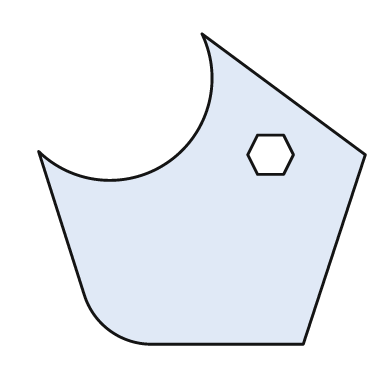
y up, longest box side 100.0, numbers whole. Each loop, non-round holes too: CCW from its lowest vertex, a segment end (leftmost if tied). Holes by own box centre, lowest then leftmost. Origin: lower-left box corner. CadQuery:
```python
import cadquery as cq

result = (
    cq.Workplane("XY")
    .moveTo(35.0, 0.0)
    .lineTo(81.0, 0.0)
    .lineTo(100.0, 58.0)
    .lineTo(50.0, 95.0)
    .threePointArc((40.0, 56.0), (0.0, 59.0))
    .lineTo(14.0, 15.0)
    .threePointArc((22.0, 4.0), (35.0, 0.0))
    .close()
    .moveTo(67.0, 52.0)
    .lineTo(75.0, 52.0)
    .lineTo(78.0, 58.0)
    .lineTo(75.0, 64.0)
    .lineTo(67.0, 64.0)
    .lineTo(64.0, 58.0)
    .close()
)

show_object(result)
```